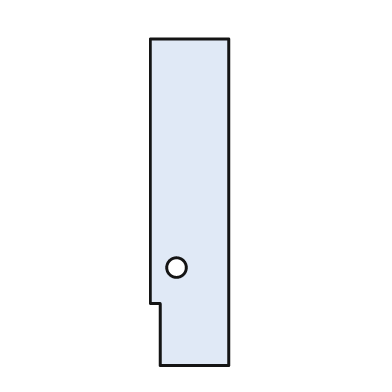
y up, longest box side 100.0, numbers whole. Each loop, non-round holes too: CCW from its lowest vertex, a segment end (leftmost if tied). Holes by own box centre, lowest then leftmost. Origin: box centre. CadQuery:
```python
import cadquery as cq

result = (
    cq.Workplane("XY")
    .moveTo(-9.0, -50.0)
    .lineTo(12.0, -50.0)
    .lineTo(12.0, 50.0)
    .lineTo(-12.0, 50.0)
    .lineTo(-12.0, -31.0)
    .lineTo(-9.0, -31.0)
    .close()
    .moveTo(-4.0, -20.0)
    .circle(3.0)
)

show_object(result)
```